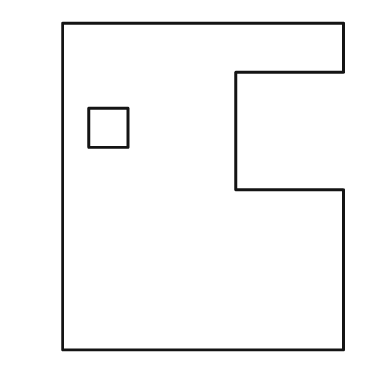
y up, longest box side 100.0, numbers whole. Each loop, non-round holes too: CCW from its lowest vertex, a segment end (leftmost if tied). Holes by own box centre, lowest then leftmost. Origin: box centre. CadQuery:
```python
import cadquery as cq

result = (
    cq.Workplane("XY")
    .moveTo(-43.0, -50.0)
    .lineTo(43.0, -50.0)
    .lineTo(43.0, -1.0)
    .lineTo(10.0, -1.0)
    .lineTo(10.0, 35.0)
    .lineTo(43.0, 35.0)
    .lineTo(43.0, 50.0)
    .lineTo(-43.0, 50.0)
    .close()
    .moveTo(-35.0, 12.0)
    .lineTo(-23.0, 12.0)
    .lineTo(-23.0, 24.0)
    .lineTo(-35.0, 24.0)
    .close()
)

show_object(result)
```